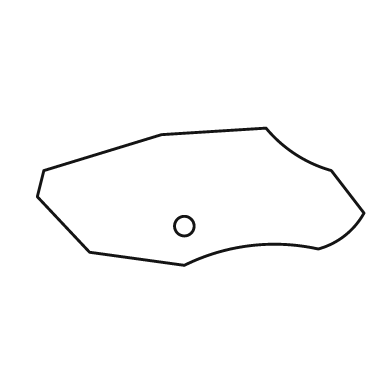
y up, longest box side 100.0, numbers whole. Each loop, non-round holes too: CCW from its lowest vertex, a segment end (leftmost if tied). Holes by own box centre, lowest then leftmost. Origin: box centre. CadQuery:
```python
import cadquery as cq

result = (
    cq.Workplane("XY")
    .moveTo(-5.0, -21.0)
    .threePointArc((15.0, -15.0), (36.0, -16.0))
    .threePointArc((44.0, -12.0), (50.0, -5.0))
    .lineTo(40.0, 8.0)
    .threePointArc((29.0, 13.0), (20.0, 21.0))
    .lineTo(-12.0, 19.0)
    .lineTo(-48.0, 8.0)
    .lineTo(-50.0, 0.0)
    .lineTo(-34.0, -17.0)
    .close()
    .moveTo(-5.0, -9.0)
    .circle(3.0)
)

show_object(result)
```